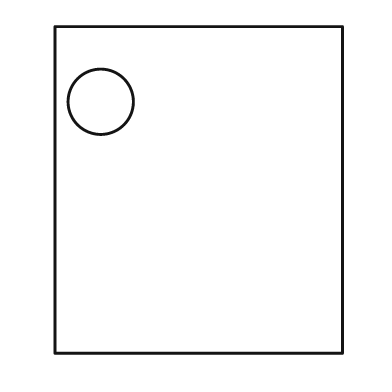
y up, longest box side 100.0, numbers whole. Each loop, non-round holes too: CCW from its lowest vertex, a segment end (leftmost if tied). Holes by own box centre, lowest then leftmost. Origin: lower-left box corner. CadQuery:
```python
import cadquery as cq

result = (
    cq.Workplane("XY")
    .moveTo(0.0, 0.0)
    .lineTo(88.0, 0.0)
    .lineTo(88.0, 100.0)
    .lineTo(0.0, 100.0)
    .close()
    .moveTo(14.0, 77.0)
    .circle(10.0)
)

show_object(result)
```